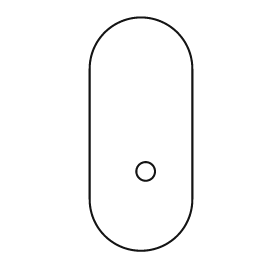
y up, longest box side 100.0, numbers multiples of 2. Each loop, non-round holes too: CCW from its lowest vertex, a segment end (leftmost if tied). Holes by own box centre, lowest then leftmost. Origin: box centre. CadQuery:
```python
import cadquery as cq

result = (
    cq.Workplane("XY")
    .moveTo(-22.0, -28.0)
    .threePointArc((0.0, -50.0), (22.0, -28.0))
    .lineTo(22.0, 28.0)
    .threePointArc((0.0, 50.0), (-22.0, 28.0))
    .close()
    .moveTo(2.0, -16.0)
    .circle(4.0)
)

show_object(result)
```